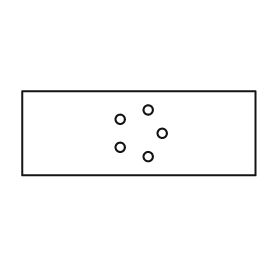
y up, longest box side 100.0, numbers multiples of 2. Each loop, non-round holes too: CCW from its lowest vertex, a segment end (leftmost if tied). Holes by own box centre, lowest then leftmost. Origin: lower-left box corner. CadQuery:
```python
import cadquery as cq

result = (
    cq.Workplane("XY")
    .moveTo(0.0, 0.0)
    .lineTo(100.0, 0.0)
    .lineTo(100.0, 36.0)
    .lineTo(0.0, 36.0)
    .close()
    .moveTo(54.0, 8.0)
    .circle(2.0)
    .moveTo(42.0, 12.0)
    .circle(2.0)
    .moveTo(60.0, 18.0)
    .circle(2.0)
    .moveTo(42.0, 24.0)
    .circle(2.0)
    .moveTo(54.0, 28.0)
    .circle(2.0)
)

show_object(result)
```